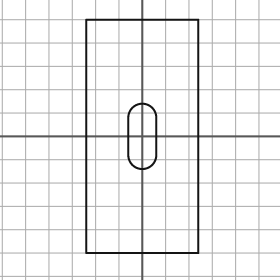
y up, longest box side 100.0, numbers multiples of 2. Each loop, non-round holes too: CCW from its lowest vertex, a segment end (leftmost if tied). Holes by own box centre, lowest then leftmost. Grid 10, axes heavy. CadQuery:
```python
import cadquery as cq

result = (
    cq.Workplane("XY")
    .moveTo(-24.0, -50.0)
    .lineTo(24.0, -50.0)
    .lineTo(24.0, 50.0)
    .lineTo(-24.0, 50.0)
    .close()
    .moveTo(-6.0, -8.0)
    .threePointArc((0.0, -14.0), (6.0, -8.0))
    .lineTo(6.0, 8.0)
    .threePointArc((0.0, 14.0), (-6.0, 8.0))
    .close()
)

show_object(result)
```